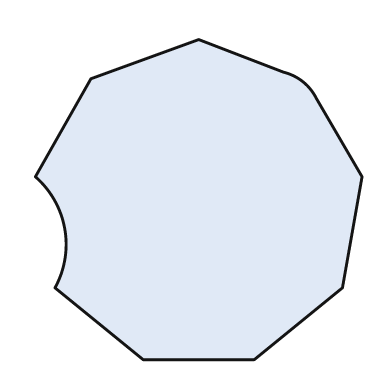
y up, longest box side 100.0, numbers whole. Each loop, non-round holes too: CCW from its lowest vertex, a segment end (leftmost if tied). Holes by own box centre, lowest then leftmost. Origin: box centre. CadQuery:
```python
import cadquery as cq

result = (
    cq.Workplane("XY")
    .moveTo(-17.0, -49.0)
    .lineTo(17.0, -49.0)
    .lineTo(44.0, -27.0)
    .lineTo(50.0, 7.0)
    .lineTo(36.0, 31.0)
    .threePointArc((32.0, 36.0), (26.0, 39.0))
    .lineTo(0.0, 49.0)
    .lineTo(-33.0, 37.0)
    .lineTo(-50.0, 7.0)
    .threePointArc((-41.0, -9.0), (-44.0, -27.0))
    .close()
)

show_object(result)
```